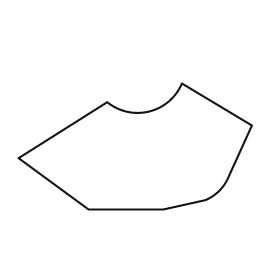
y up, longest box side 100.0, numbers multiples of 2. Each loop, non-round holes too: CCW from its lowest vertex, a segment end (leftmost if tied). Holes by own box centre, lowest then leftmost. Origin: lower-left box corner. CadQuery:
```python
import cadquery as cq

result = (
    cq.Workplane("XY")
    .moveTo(30.0, 0.0)
    .lineTo(62.0, 0.0)
    .lineTo(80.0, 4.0)
    .threePointArc((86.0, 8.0), (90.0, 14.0))
    .lineTo(100.0, 36.0)
    .lineTo(70.0, 54.0)
    .threePointArc((56.0, 42.0), (38.0, 46.0))
    .lineTo(0.0, 22.0)
    .close()
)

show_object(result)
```